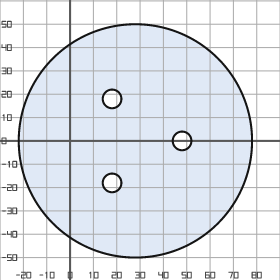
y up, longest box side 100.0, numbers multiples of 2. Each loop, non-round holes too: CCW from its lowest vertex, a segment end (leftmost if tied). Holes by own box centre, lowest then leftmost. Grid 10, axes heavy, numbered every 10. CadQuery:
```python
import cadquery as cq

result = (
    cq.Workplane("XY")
    .moveTo(28.0, 0.0)
    .circle(50.0)
    .moveTo(18.0, -18.0)
    .circle(4.0)
    .moveTo(48.0, 0.0)
    .circle(4.0)
    .moveTo(18.0, 18.0)
    .circle(4.0)
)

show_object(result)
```